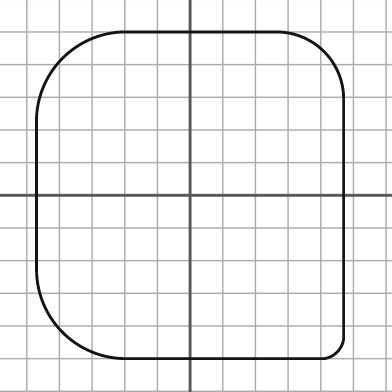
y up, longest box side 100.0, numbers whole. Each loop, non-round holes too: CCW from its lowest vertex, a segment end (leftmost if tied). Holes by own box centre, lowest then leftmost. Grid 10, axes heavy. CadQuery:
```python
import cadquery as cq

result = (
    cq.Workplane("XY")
    .moveTo(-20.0, -50.0)
    .lineTo(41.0, -50.0)
    .threePointArc((45.0, -48.0), (47.0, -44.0))
    .lineTo(47.0, 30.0)
    .threePointArc((41.0, 44.0), (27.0, 50.0))
    .lineTo(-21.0, 50.0)
    .threePointArc((-39.0, 42.0), (-47.0, 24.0))
    .lineTo(-47.0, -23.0)
    .threePointArc((-39.0, -42.0), (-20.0, -50.0))
    .close()
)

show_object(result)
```